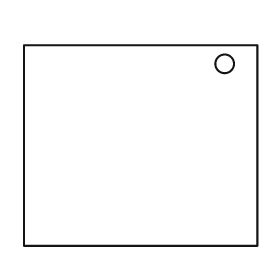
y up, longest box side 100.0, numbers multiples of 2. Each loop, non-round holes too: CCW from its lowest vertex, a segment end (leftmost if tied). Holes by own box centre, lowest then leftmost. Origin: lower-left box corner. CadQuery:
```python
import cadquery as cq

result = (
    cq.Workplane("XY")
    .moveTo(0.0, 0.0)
    .lineTo(100.0, 0.0)
    .lineTo(100.0, 86.0)
    .lineTo(0.0, 86.0)
    .close()
    .moveTo(86.0, 78.0)
    .circle(4.0)
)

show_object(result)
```